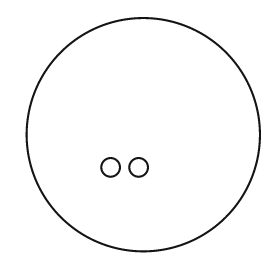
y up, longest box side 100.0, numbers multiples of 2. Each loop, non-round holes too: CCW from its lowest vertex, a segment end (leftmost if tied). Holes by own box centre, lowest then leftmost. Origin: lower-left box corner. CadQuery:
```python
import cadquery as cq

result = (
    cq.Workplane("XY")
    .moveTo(50.0, 50.0)
    .circle(50.0)
    .moveTo(36.0, 36.0)
    .circle(4.0)
    .moveTo(48.0, 36.0)
    .circle(4.0)
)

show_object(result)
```